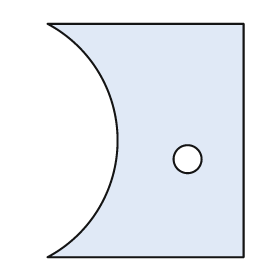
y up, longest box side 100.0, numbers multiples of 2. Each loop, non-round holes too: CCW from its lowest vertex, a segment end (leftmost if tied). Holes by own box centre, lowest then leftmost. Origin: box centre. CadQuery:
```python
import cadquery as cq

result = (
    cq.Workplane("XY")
    .moveTo(-42.0, -50.0)
    .lineTo(42.0, -50.0)
    .lineTo(42.0, 50.0)
    .lineTo(-42.0, 50.0)
    .threePointArc((-12.0, 0.0), (-42.0, -50.0))
    .close()
    .moveTo(18.0, -8.0)
    .circle(6.0)
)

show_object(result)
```